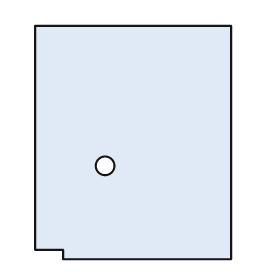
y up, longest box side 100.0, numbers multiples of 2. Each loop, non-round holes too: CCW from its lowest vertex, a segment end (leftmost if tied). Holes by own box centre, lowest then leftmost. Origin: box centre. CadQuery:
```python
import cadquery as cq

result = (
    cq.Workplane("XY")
    .moveTo(-30.0, -50.0)
    .lineTo(42.0, -50.0)
    .lineTo(42.0, 50.0)
    .lineTo(-42.0, 50.0)
    .lineTo(-42.0, -46.0)
    .lineTo(-30.0, -46.0)
    .close()
    .moveTo(-12.0, -10.0)
    .circle(4.0)
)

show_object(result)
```